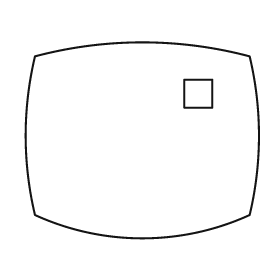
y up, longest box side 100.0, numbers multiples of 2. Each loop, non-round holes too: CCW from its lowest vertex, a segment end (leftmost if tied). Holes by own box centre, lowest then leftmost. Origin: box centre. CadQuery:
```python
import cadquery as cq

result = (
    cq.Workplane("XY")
    .moveTo(-46.0, -32.0)
    .threePointArc((0.0, -42.0), (46.0, -32.0))
    .threePointArc((50.0, 2.0), (46.0, 36.0))
    .threePointArc((0.0, 42.0), (-46.0, 36.0))
    .threePointArc((-50.0, 2.0), (-46.0, -32.0))
    .close()
    .moveTo(18.0, 14.0)
    .lineTo(30.0, 14.0)
    .lineTo(30.0, 26.0)
    .lineTo(18.0, 26.0)
    .close()
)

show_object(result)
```